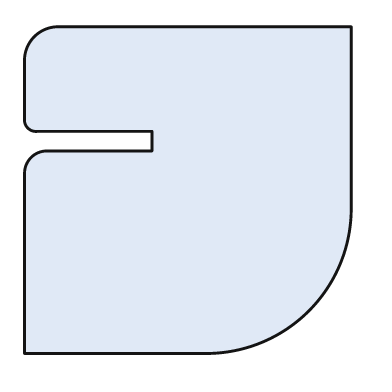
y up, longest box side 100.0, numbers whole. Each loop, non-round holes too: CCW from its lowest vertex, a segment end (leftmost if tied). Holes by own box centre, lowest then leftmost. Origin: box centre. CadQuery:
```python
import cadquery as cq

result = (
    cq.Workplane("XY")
    .moveTo(-50.0, -50.0)
    .lineTo(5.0, -50.0)
    .threePointArc((37.0, -37.0), (50.0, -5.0))
    .lineTo(50.0, 50.0)
    .lineTo(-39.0, 50.0)
    .threePointArc((-47.0, 47.0), (-50.0, 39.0))
    .lineTo(-50.0, 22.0)
    .threePointArc((-49.0, 19.0), (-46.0, 18.0))
    .lineTo(-11.0, 18.0)
    .lineTo(-11.0, 12.0)
    .lineTo(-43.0, 12.0)
    .threePointArc((-48.0, 10.0), (-50.0, 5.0))
    .close()
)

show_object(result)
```